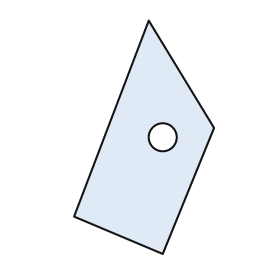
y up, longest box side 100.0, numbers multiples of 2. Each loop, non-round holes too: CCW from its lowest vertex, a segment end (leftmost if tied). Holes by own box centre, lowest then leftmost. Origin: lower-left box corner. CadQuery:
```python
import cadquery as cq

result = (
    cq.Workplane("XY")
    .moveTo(38.0, 0.0)
    .lineTo(60.0, 54.0)
    .lineTo(32.0, 100.0)
    .lineTo(0.0, 16.0)
    .close()
    .moveTo(38.0, 50.0)
    .circle(6.0)
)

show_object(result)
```